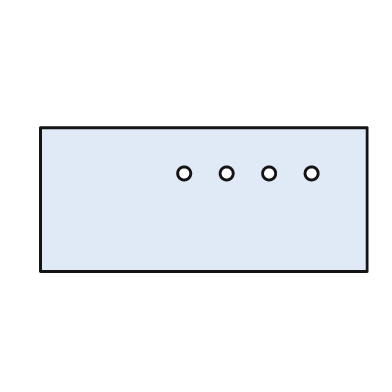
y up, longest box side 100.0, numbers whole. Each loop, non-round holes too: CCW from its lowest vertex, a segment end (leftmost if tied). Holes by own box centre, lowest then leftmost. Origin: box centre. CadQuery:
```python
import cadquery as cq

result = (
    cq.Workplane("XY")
    .moveTo(-50.0, -22.0)
    .lineTo(50.0, -22.0)
    .lineTo(50.0, 22.0)
    .lineTo(-50.0, 22.0)
    .close()
    .moveTo(-6.0, 8.0)
    .circle(2.0)
    .moveTo(7.0, 8.0)
    .circle(2.0)
    .moveTo(20.0, 8.0)
    .circle(2.0)
    .moveTo(33.0, 8.0)
    .circle(2.0)
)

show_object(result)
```